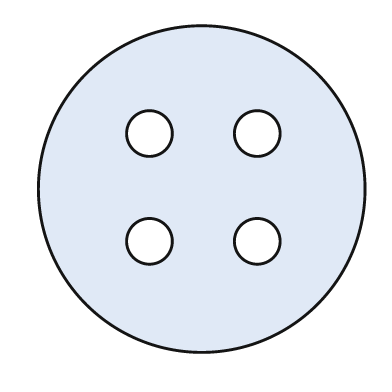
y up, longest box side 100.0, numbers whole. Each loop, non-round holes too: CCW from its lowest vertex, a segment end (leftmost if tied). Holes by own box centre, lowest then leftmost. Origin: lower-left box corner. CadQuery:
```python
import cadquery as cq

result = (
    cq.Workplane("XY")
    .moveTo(50.0, 50.0)
    .circle(50.0)
    .moveTo(34.0, 34.0)
    .circle(7.0)
    .moveTo(67.0, 34.0)
    .circle(7.0)
    .moveTo(34.0, 67.0)
    .circle(7.0)
    .moveTo(67.0, 67.0)
    .circle(7.0)
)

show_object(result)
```